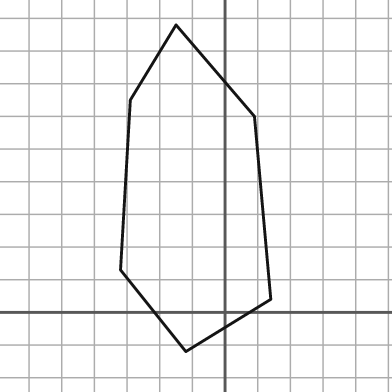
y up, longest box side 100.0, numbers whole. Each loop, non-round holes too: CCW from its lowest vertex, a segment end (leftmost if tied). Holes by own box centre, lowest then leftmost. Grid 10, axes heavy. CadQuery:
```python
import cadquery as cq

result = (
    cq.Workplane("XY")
    .moveTo(-12.0, -12.0)
    .lineTo(14.0, 4.0)
    .lineTo(9.0, 60.0)
    .lineTo(-15.0, 88.0)
    .lineTo(-29.0, 65.0)
    .lineTo(-32.0, 13.0)
    .close()
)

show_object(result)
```